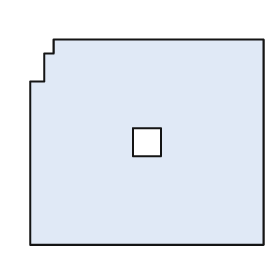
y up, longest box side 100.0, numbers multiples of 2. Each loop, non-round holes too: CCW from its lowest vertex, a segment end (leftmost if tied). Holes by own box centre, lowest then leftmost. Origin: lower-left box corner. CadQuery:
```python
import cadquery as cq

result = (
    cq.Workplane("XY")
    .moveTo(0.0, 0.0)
    .lineTo(100.0, 0.0)
    .lineTo(100.0, 88.0)
    .lineTo(10.0, 88.0)
    .lineTo(10.0, 82.0)
    .lineTo(6.0, 82.0)
    .lineTo(6.0, 70.0)
    .lineTo(0.0, 70.0)
    .close()
    .moveTo(44.0, 38.0)
    .lineTo(56.0, 38.0)
    .lineTo(56.0, 50.0)
    .lineTo(44.0, 50.0)
    .close()
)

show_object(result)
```